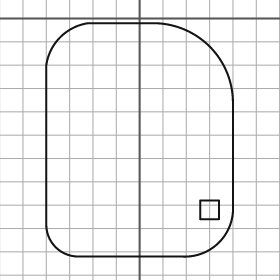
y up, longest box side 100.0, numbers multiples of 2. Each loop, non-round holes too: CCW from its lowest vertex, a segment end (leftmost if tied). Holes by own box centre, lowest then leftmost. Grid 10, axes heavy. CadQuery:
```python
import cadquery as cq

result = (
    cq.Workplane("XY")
    .moveTo(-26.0, -102.0)
    .lineTo(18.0, -102.0)
    .threePointArc((34.0, -96.0), (40.0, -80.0))
    .lineTo(40.0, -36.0)
    .threePointArc((30.0, -12.0), (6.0, -2.0))
    .lineTo(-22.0, -2.0)
    .threePointArc((-34.0, -8.0), (-40.0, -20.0))
    .lineTo(-40.0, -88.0)
    .threePointArc((-36.0, -98.0), (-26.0, -102.0))
    .close()
    .moveTo(26.0, -86.0)
    .lineTo(34.0, -86.0)
    .lineTo(34.0, -78.0)
    .lineTo(26.0, -78.0)
    .close()
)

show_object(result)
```